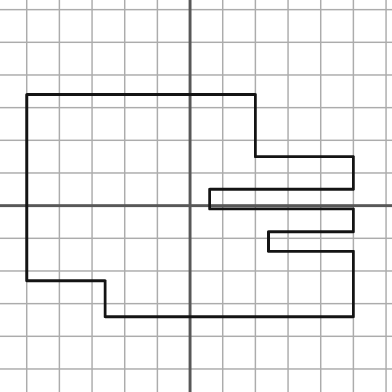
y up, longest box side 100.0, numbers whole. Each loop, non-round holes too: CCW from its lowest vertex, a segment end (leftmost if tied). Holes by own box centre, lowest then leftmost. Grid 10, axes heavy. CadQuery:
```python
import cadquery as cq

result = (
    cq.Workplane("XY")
    .moveTo(-26.0, -34.0)
    .lineTo(50.0, -34.0)
    .lineTo(50.0, -14.0)
    .lineTo(24.0, -14.0)
    .lineTo(24.0, -8.0)
    .lineTo(50.0, -8.0)
    .lineTo(50.0, -1.0)
    .lineTo(6.0, -1.0)
    .lineTo(6.0, 5.0)
    .lineTo(50.0, 5.0)
    .lineTo(50.0, 15.0)
    .lineTo(20.0, 15.0)
    .lineTo(20.0, 34.0)
    .lineTo(-50.0, 34.0)
    .lineTo(-50.0, -23.0)
    .lineTo(-26.0, -23.0)
    .close()
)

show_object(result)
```